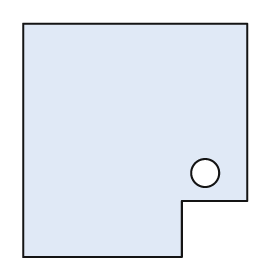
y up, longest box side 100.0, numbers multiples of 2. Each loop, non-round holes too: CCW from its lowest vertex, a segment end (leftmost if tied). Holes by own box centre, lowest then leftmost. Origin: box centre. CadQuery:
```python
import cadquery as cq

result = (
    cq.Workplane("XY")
    .moveTo(-48.0, -50.0)
    .lineTo(20.0, -50.0)
    .lineTo(20.0, -26.0)
    .lineTo(48.0, -26.0)
    .lineTo(48.0, 50.0)
    .lineTo(-48.0, 50.0)
    .close()
    .moveTo(30.0, -14.0)
    .circle(6.0)
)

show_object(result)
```